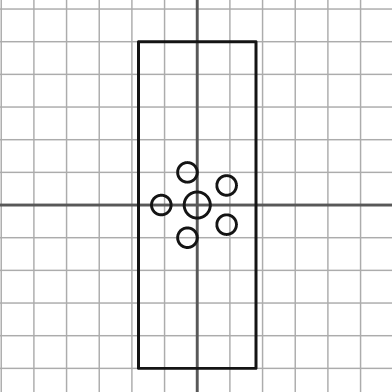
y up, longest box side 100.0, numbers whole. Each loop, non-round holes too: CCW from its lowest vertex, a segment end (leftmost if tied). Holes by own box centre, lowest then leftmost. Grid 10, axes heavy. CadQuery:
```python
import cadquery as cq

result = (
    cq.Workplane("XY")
    .moveTo(-18.0, -50.0)
    .lineTo(18.0, -50.0)
    .lineTo(18.0, 50.0)
    .lineTo(-18.0, 50.0)
    .close()
    .moveTo(-3.0, -10.0)
    .circle(3.0)
    .moveTo(9.0, -6.0)
    .circle(3.0)
    .moveTo(-11.0, 0.0)
    .circle(3.0)
    .moveTo(0.0, 0.0)
    .circle(4.0)
    .moveTo(9.0, 6.0)
    .circle(3.0)
    .moveTo(-3.0, 10.0)
    .circle(3.0)
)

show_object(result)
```